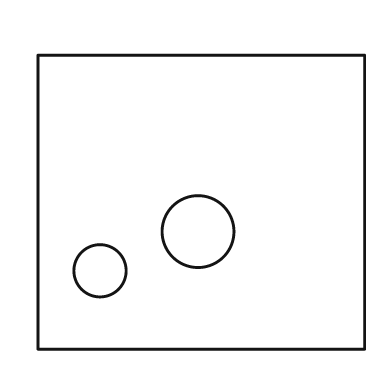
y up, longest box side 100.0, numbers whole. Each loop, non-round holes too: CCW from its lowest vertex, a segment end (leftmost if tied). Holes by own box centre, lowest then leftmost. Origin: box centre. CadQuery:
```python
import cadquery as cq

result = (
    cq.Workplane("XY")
    .moveTo(-50.0, -45.0)
    .lineTo(50.0, -45.0)
    .lineTo(50.0, 45.0)
    .lineTo(-50.0, 45.0)
    .close()
    .moveTo(-31.0, -21.0)
    .circle(8.0)
    .moveTo(-1.0, -9.0)
    .circle(11.0)
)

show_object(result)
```